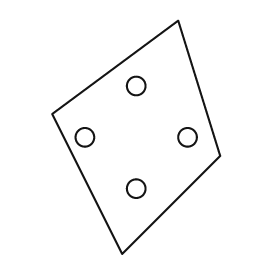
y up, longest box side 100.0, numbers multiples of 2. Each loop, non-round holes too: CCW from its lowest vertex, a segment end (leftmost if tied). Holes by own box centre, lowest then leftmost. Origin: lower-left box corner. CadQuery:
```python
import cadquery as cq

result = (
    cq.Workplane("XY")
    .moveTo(30.0, 0.0)
    .lineTo(72.0, 42.0)
    .lineTo(54.0, 100.0)
    .lineTo(0.0, 60.0)
    .close()
    .moveTo(36.0, 28.0)
    .circle(4.0)
    .moveTo(14.0, 50.0)
    .circle(4.0)
    .moveTo(58.0, 50.0)
    .circle(4.0)
    .moveTo(36.0, 72.0)
    .circle(4.0)
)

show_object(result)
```